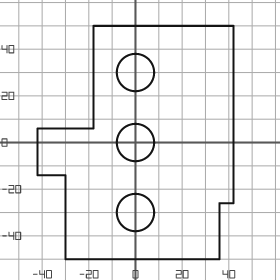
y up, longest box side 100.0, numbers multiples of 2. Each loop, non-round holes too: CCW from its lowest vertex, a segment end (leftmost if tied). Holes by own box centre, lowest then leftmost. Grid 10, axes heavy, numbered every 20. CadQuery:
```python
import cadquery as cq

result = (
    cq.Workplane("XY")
    .moveTo(-30.0, -50.0)
    .lineTo(36.0, -50.0)
    .lineTo(36.0, -26.0)
    .lineTo(42.0, -26.0)
    .lineTo(42.0, 50.0)
    .lineTo(-18.0, 50.0)
    .lineTo(-18.0, 6.0)
    .lineTo(-42.0, 6.0)
    .lineTo(-42.0, -14.0)
    .lineTo(-30.0, -14.0)
    .close()
    .moveTo(0.0, -30.0)
    .circle(8.0)
    .moveTo(0.0, 0.0)
    .circle(8.0)
    .moveTo(0.0, 30.0)
    .circle(8.0)
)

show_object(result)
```